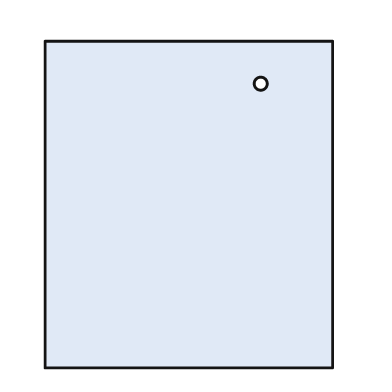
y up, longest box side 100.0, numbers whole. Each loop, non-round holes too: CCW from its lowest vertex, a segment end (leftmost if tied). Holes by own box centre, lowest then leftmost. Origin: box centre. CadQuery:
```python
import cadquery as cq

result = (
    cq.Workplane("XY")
    .moveTo(-44.0, -50.0)
    .lineTo(44.0, -50.0)
    .lineTo(44.0, 50.0)
    .lineTo(-44.0, 50.0)
    .close()
    .moveTo(22.0, 37.0)
    .circle(2.0)
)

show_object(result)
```